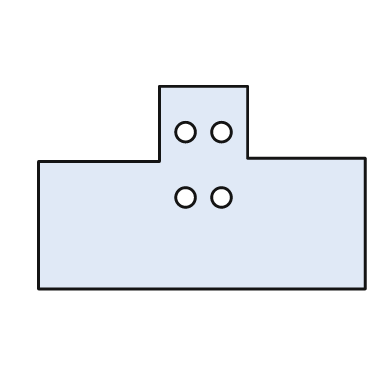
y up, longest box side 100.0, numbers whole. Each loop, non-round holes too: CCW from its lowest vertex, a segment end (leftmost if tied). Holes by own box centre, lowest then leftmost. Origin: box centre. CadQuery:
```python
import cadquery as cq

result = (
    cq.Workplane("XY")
    .moveTo(-50.0, -31.0)
    .lineTo(50.0, -31.0)
    .lineTo(50.0, 9.0)
    .lineTo(14.0, 9.0)
    .lineTo(14.0, 31.0)
    .lineTo(-13.0, 31.0)
    .lineTo(-13.0, 8.0)
    .lineTo(-50.0, 8.0)
    .close()
    .moveTo(-5.0, -3.0)
    .circle(3.0)
    .moveTo(6.0, -3.0)
    .circle(3.0)
    .moveTo(-5.0, 17.0)
    .circle(3.0)
    .moveTo(6.0, 17.0)
    .circle(3.0)
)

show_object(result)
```